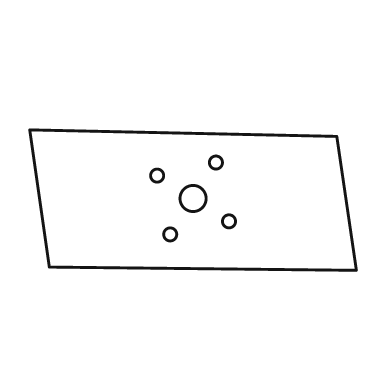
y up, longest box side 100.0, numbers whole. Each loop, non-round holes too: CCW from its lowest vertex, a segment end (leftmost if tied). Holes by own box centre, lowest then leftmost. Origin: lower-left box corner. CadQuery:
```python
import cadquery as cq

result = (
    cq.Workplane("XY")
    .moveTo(100.0, 0.0)
    .lineTo(94.0, 41.0)
    .lineTo(0.0, 43.0)
    .lineTo(6.0, 1.0)
    .close()
    .moveTo(43.0, 11.0)
    .circle(2.0)
    .moveTo(61.0, 15.0)
    .circle(2.0)
    .moveTo(50.0, 22.0)
    .circle(4.0)
    .moveTo(39.0, 29.0)
    .circle(2.0)
    .moveTo(57.0, 33.0)
    .circle(2.0)
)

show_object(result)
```